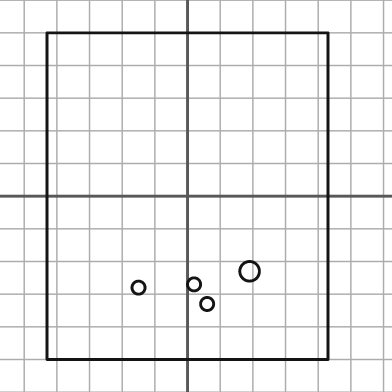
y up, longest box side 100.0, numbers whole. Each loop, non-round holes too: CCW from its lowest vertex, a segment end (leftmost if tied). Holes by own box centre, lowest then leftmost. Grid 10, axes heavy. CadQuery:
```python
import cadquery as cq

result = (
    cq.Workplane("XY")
    .moveTo(-43.0, -50.0)
    .lineTo(43.0, -50.0)
    .lineTo(43.0, 50.0)
    .lineTo(-43.0, 50.0)
    .close()
    .moveTo(6.0, -33.0)
    .circle(2.0)
    .moveTo(-15.0, -28.0)
    .circle(2.0)
    .moveTo(2.0, -27.0)
    .circle(2.0)
    .moveTo(19.0, -23.0)
    .circle(3.0)
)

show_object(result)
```